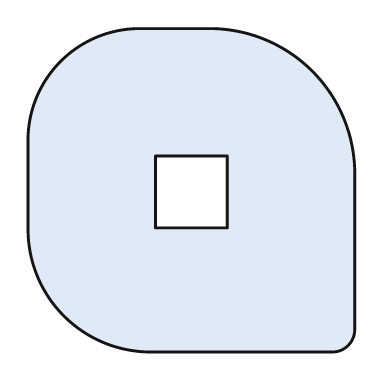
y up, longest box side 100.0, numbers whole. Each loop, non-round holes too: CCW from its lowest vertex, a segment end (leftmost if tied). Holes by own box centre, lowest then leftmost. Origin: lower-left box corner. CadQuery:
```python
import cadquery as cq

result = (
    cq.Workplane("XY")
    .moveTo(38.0, 0.0)
    .lineTo(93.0, 0.0)
    .threePointArc((98.0, 2.0), (100.0, 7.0))
    .lineTo(100.0, 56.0)
    .threePointArc((87.0, 86.0), (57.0, 99.0))
    .lineTo(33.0, 99.0)
    .threePointArc((10.0, 89.0), (0.0, 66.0))
    .lineTo(0.0, 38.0)
    .threePointArc((11.0, 11.0), (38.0, 0.0))
    .close()
    .moveTo(39.0, 38.0)
    .lineTo(61.0, 38.0)
    .lineTo(61.0, 60.0)
    .lineTo(39.0, 60.0)
    .close()
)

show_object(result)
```